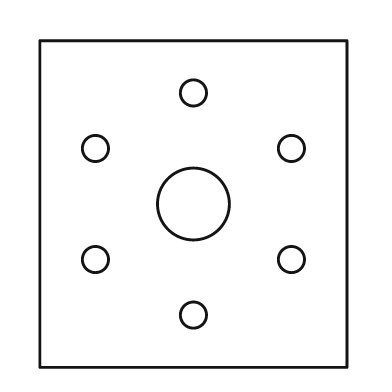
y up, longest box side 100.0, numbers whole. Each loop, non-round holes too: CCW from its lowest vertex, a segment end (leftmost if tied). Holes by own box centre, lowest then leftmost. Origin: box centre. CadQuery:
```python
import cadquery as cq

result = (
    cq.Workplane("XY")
    .moveTo(-47.0, -50.0)
    .lineTo(47.0, -50.0)
    .lineTo(47.0, 50.0)
    .lineTo(-47.0, 50.0)
    .close()
    .moveTo(0.0, -34.0)
    .circle(4.0)
    .moveTo(-30.0, -17.0)
    .circle(4.0)
    .moveTo(30.0, -17.0)
    .circle(4.0)
    .moveTo(0.0, 0.0)
    .circle(11.0)
    .moveTo(-30.0, 17.0)
    .circle(4.0)
    .moveTo(30.0, 17.0)
    .circle(4.0)
    .moveTo(0.0, 34.0)
    .circle(4.0)
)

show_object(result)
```